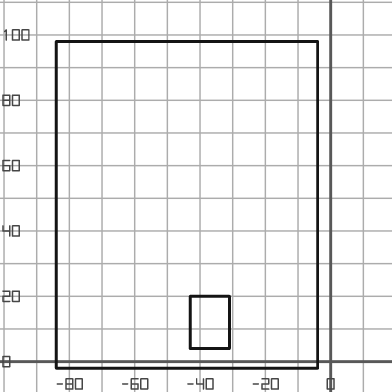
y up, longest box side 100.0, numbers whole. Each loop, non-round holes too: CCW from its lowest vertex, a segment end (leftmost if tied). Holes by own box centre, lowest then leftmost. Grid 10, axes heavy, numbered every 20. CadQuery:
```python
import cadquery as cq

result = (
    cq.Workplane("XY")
    .moveTo(-84.0, -2.0)
    .lineTo(-4.0, -2.0)
    .lineTo(-4.0, 98.0)
    .lineTo(-84.0, 98.0)
    .close()
    .moveTo(-43.0, 4.0)
    .lineTo(-31.0, 4.0)
    .lineTo(-31.0, 20.0)
    .lineTo(-43.0, 20.0)
    .close()
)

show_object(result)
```